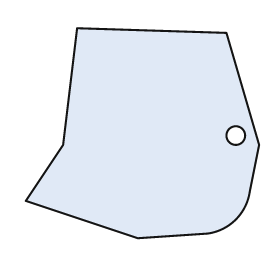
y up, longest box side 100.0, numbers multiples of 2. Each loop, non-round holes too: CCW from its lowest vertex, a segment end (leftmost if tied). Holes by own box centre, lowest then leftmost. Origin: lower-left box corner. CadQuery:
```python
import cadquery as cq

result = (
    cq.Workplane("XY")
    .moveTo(48.0, 0.0)
    .lineTo(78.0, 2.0)
    .threePointArc((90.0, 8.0), (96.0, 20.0))
    .lineTo(100.0, 40.0)
    .lineTo(86.0, 88.0)
    .lineTo(22.0, 90.0)
    .lineTo(16.0, 40.0)
    .lineTo(0.0, 16.0)
    .close()
    .moveTo(90.0, 44.0)
    .circle(4.0)
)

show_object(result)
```